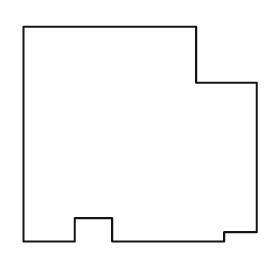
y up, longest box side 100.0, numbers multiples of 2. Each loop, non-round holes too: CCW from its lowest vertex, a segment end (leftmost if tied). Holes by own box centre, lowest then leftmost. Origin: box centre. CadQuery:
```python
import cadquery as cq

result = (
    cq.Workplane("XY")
    .moveTo(-50.0, -46.0)
    .lineTo(-28.0, -46.0)
    .lineTo(-28.0, -36.0)
    .lineTo(-12.0, -36.0)
    .lineTo(-12.0, -46.0)
    .lineTo(36.0, -46.0)
    .lineTo(36.0, -42.0)
    .lineTo(50.0, -42.0)
    .lineTo(50.0, 22.0)
    .lineTo(24.0, 22.0)
    .lineTo(24.0, 46.0)
    .lineTo(-50.0, 46.0)
    .close()
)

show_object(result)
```